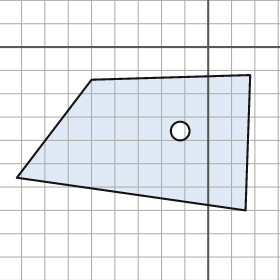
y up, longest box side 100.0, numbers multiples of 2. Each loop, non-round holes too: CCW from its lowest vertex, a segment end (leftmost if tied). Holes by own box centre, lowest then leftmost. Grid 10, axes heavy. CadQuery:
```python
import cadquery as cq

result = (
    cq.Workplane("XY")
    .moveTo(16.0, -70.0)
    .lineTo(18.0, -12.0)
    .lineTo(-50.0, -14.0)
    .lineTo(-82.0, -56.0)
    .close()
    .moveTo(-12.0, -36.0)
    .circle(4.0)
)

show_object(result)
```